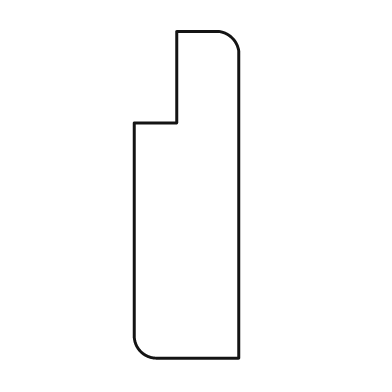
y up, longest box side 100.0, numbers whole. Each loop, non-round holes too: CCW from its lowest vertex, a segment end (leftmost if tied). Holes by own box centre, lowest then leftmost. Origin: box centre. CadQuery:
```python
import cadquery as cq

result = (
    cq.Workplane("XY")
    .moveTo(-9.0, -50.0)
    .lineTo(16.0, -50.0)
    .lineTo(16.0, 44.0)
    .threePointArc((14.0, 48.0), (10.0, 50.0))
    .lineTo(-3.0, 50.0)
    .lineTo(-3.0, 22.0)
    .lineTo(-16.0, 22.0)
    .lineTo(-16.0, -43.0)
    .threePointArc((-14.0, -48.0), (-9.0, -50.0))
    .close()
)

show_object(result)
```